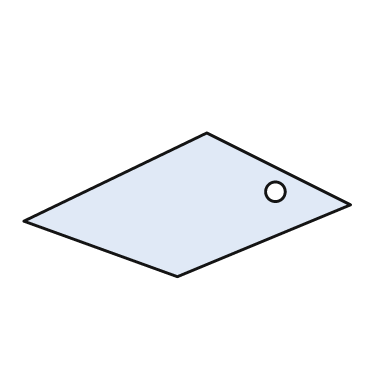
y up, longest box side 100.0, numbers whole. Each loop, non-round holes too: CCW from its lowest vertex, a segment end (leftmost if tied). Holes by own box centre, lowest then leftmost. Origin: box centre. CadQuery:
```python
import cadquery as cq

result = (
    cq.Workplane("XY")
    .moveTo(-3.0, -22.0)
    .lineTo(50.0, 0.0)
    .lineTo(6.0, 22.0)
    .lineTo(-50.0, -5.0)
    .close()
    .moveTo(27.0, 4.0)
    .circle(3.0)
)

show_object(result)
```